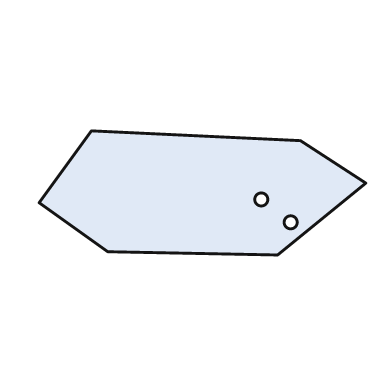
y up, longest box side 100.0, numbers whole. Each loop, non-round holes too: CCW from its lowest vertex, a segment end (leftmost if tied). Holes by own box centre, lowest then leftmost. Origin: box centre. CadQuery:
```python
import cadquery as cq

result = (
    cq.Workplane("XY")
    .moveTo(23.0, -19.0)
    .lineTo(50.0, 3.0)
    .lineTo(30.0, 16.0)
    .lineTo(-34.0, 19.0)
    .lineTo(-50.0, -3.0)
    .lineTo(-29.0, -18.0)
    .close()
    .moveTo(27.0, -9.0)
    .circle(2.0)
    .moveTo(18.0, -2.0)
    .circle(2.0)
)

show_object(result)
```